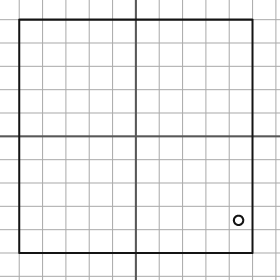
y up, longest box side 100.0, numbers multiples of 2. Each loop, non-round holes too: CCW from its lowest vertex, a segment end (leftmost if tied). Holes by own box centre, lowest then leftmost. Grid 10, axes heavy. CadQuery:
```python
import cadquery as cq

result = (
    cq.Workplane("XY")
    .moveTo(-50.0, -50.0)
    .lineTo(50.0, -50.0)
    .lineTo(50.0, 50.0)
    .lineTo(-50.0, 50.0)
    .close()
    .moveTo(44.0, -36.0)
    .circle(2.0)
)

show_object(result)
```